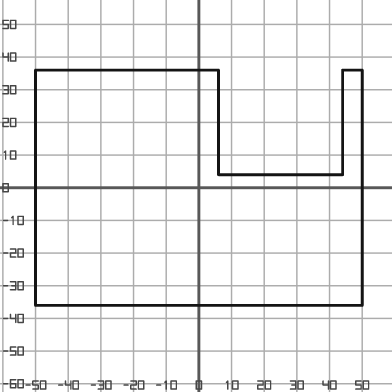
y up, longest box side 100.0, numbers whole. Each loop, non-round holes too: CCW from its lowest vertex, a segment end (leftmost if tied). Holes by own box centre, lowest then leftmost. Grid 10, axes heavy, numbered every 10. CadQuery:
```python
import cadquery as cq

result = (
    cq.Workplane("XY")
    .moveTo(-50.0, -36.0)
    .lineTo(50.0, -36.0)
    .lineTo(50.0, 36.0)
    .lineTo(44.0, 36.0)
    .lineTo(44.0, 4.0)
    .lineTo(6.0, 4.0)
    .lineTo(6.0, 36.0)
    .lineTo(-50.0, 36.0)
    .close()
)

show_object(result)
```